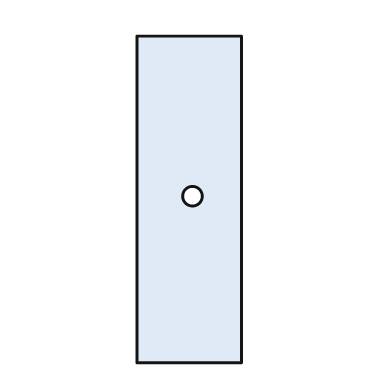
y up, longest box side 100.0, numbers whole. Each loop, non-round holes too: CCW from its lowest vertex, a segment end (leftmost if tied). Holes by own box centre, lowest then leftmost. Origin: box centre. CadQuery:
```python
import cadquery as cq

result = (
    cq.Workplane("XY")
    .moveTo(-16.0, -50.0)
    .lineTo(16.0, -50.0)
    .lineTo(16.0, 50.0)
    .lineTo(-16.0, 50.0)
    .close()
    .moveTo(1.0, 1.0)
    .circle(3.0)
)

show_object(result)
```